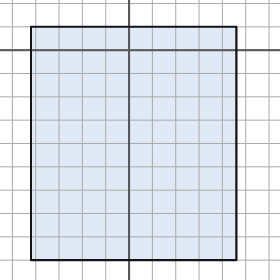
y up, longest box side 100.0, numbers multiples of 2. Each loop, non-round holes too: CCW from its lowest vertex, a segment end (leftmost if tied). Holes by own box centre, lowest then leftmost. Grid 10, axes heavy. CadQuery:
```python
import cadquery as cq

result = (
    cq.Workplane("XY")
    .moveTo(-42.0, -90.0)
    .lineTo(46.0, -90.0)
    .lineTo(46.0, 10.0)
    .lineTo(-42.0, 10.0)
    .close()
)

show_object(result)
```